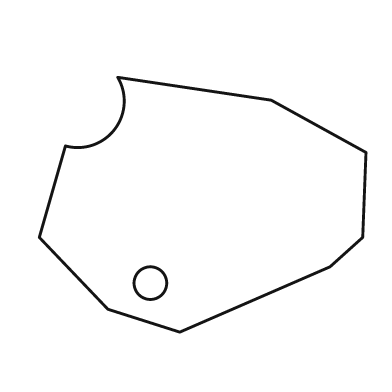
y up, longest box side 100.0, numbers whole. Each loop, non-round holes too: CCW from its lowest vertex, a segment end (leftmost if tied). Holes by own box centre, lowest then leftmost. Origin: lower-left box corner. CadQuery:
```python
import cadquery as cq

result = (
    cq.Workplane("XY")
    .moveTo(43.0, 0.0)
    .lineTo(89.0, 20.0)
    .lineTo(99.0, 29.0)
    .lineTo(100.0, 55.0)
    .lineTo(71.0, 71.0)
    .lineTo(24.0, 78.0)
    .threePointArc((23.0, 62.0), (8.0, 57.0))
    .lineTo(0.0, 29.0)
    .lineTo(21.0, 7.0)
    .close()
    .moveTo(34.0, 15.0)
    .circle(5.0)
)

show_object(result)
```